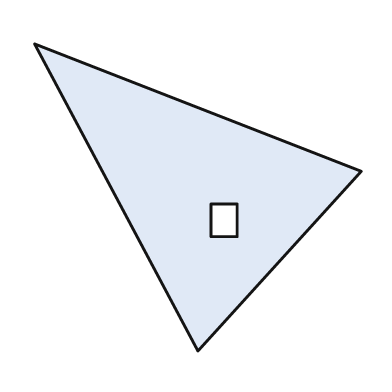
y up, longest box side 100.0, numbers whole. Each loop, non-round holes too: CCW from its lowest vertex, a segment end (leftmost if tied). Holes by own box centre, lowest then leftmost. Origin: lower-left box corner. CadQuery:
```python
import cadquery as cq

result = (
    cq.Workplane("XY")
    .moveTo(50.0, 0.0)
    .lineTo(100.0, 55.0)
    .lineTo(0.0, 94.0)
    .close()
    .moveTo(54.0, 35.0)
    .lineTo(62.0, 35.0)
    .lineTo(62.0, 45.0)
    .lineTo(54.0, 45.0)
    .close()
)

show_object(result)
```